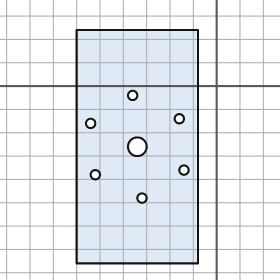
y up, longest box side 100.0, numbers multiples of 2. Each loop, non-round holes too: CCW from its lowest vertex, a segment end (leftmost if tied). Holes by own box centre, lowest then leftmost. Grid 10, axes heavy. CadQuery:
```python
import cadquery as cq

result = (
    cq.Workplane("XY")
    .moveTo(-60.0, -76.0)
    .lineTo(-8.0, -76.0)
    .lineTo(-8.0, 24.0)
    .lineTo(-60.0, 24.0)
    .close()
    .moveTo(-32.0, -48.0)
    .circle(2.0)
    .moveTo(-52.0, -38.0)
    .circle(2.0)
    .moveTo(-14.0, -36.0)
    .circle(2.0)
    .moveTo(-34.0, -26.0)
    .circle(4.0)
    .moveTo(-54.0, -16.0)
    .circle(2.0)
    .moveTo(-16.0, -14.0)
    .circle(2.0)
    .moveTo(-36.0, -4.0)
    .circle(2.0)
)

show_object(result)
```